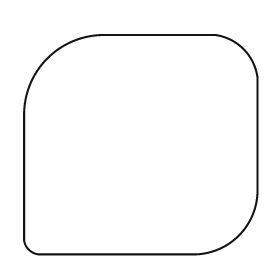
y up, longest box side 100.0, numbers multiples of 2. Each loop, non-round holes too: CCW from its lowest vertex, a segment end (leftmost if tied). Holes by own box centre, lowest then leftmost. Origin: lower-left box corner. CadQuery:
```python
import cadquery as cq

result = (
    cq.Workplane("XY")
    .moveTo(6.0, 0.0)
    .lineTo(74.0, 0.0)
    .threePointArc((92.0, 8.0), (100.0, 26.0))
    .lineTo(100.0, 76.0)
    .threePointArc((94.0, 88.0), (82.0, 94.0))
    .lineTo(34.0, 94.0)
    .threePointArc((10.0, 84.0), (0.0, 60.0))
    .lineTo(0.0, 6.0)
    .threePointArc((2.0, 2.0), (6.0, 0.0))
    .close()
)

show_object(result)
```